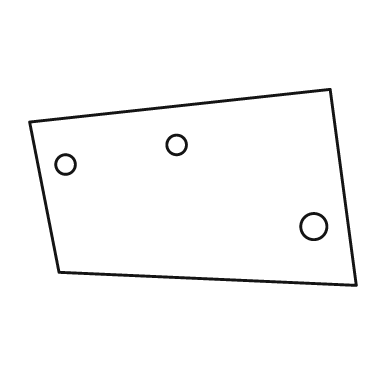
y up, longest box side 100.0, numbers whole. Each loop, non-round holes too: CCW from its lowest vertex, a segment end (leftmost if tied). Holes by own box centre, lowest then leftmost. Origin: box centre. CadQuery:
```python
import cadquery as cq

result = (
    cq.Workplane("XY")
    .moveTo(50.0, -30.0)
    .lineTo(42.0, 30.0)
    .lineTo(-50.0, 20.0)
    .lineTo(-41.0, -26.0)
    .close()
    .moveTo(37.0, -12.0)
    .circle(4.0)
    .moveTo(-39.0, 7.0)
    .circle(3.0)
    .moveTo(-5.0, 13.0)
    .circle(3.0)
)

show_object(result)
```